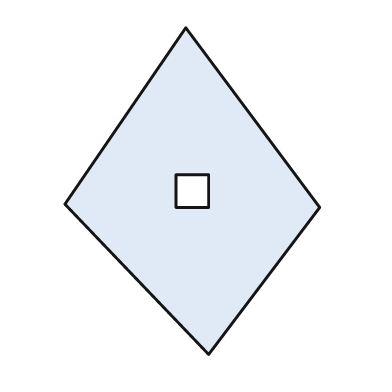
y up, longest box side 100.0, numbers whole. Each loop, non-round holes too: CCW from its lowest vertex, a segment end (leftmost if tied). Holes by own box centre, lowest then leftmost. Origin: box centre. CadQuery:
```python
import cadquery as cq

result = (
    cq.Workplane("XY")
    .moveTo(5.0, -50.0)
    .lineTo(39.0, -5.0)
    .lineTo(-2.0, 50.0)
    .lineTo(-39.0, -4.0)
    .close()
    .moveTo(-5.0, -5.0)
    .lineTo(5.0, -5.0)
    .lineTo(5.0, 5.0)
    .lineTo(-5.0, 5.0)
    .close()
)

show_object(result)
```